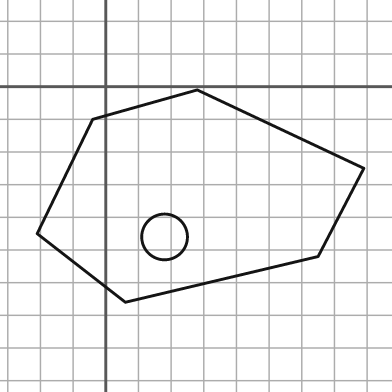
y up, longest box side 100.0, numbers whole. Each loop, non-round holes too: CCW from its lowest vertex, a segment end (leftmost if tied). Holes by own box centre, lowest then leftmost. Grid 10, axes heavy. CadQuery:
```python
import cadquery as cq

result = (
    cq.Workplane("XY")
    .moveTo(6.0, -66.0)
    .lineTo(65.0, -52.0)
    .lineTo(79.0, -25.0)
    .lineTo(28.0, -1.0)
    .lineTo(-4.0, -10.0)
    .lineTo(-21.0, -45.0)
    .close()
    .moveTo(18.0, -46.0)
    .circle(7.0)
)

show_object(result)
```